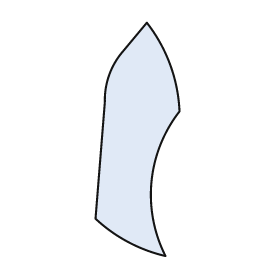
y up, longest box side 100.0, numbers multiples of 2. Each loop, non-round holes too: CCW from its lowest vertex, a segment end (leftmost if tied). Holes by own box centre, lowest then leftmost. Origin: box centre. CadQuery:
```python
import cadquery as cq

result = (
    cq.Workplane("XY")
    .moveTo(12.0, -50.0)
    .threePointArc((6.0, -18.0), (18.0, 12.0))
    .threePointArc((14.0, 32.0), (4.0, 50.0))
    .lineTo(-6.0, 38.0)
    .threePointArc((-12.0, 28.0), (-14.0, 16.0))
    .lineTo(-18.0, -34.0)
    .threePointArc((-4.0, -44.0), (12.0, -50.0))
    .close()
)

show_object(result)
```